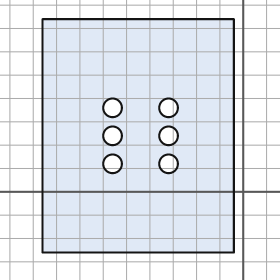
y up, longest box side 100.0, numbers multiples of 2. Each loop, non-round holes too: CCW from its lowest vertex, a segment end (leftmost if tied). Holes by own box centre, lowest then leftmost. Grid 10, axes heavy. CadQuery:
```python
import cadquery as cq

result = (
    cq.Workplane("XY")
    .moveTo(-86.0, -26.0)
    .lineTo(-4.0, -26.0)
    .lineTo(-4.0, 74.0)
    .lineTo(-86.0, 74.0)
    .close()
    .moveTo(-56.0, 12.0)
    .circle(4.0)
    .moveTo(-32.0, 12.0)
    .circle(4.0)
    .moveTo(-56.0, 24.0)
    .circle(4.0)
    .moveTo(-32.0, 24.0)
    .circle(4.0)
    .moveTo(-56.0, 36.0)
    .circle(4.0)
    .moveTo(-32.0, 36.0)
    .circle(4.0)
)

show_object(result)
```